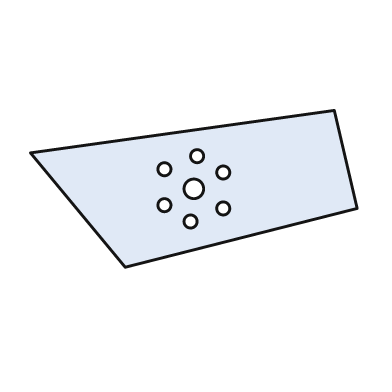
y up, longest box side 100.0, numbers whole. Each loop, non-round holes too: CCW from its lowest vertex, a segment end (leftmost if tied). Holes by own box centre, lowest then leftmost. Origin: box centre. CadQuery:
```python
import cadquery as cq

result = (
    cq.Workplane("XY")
    .moveTo(-21.0, -24.0)
    .lineTo(50.0, -6.0)
    .lineTo(43.0, 24.0)
    .lineTo(-50.0, 11.0)
    .close()
    .moveTo(-1.0, -10.0)
    .circle(2.0)
    .moveTo(9.0, -6.0)
    .circle(2.0)
    .moveTo(-9.0, -5.0)
    .circle(2.0)
    .moveTo(0.0, 0.0)
    .circle(3.0)
    .moveTo(9.0, 5.0)
    .circle(2.0)
    .moveTo(-9.0, 6.0)
    .circle(2.0)
    .moveTo(1.0, 10.0)
    .circle(2.0)
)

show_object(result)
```